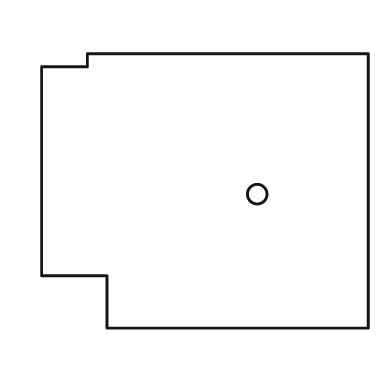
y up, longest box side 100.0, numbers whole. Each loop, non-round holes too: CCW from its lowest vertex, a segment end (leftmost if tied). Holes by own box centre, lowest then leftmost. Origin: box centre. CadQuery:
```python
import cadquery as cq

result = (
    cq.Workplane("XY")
    .moveTo(-30.0, -42.0)
    .lineTo(50.0, -42.0)
    .lineTo(50.0, 42.0)
    .lineTo(-36.0, 42.0)
    .lineTo(-36.0, 38.0)
    .lineTo(-50.0, 38.0)
    .lineTo(-50.0, -26.0)
    .lineTo(-30.0, -26.0)
    .close()
    .moveTo(16.0, -1.0)
    .circle(3.0)
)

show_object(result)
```